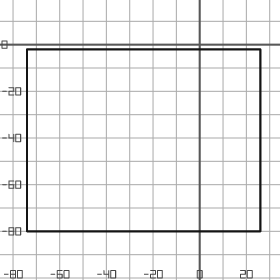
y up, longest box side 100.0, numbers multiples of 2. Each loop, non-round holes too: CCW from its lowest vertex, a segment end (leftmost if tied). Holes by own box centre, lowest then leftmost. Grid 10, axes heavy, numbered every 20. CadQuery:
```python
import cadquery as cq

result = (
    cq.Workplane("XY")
    .moveTo(-74.0, -80.0)
    .lineTo(26.0, -80.0)
    .lineTo(26.0, -2.0)
    .lineTo(-74.0, -2.0)
    .close()
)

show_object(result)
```